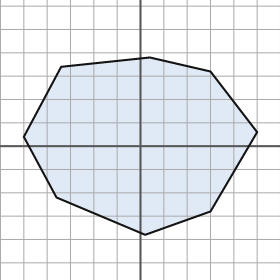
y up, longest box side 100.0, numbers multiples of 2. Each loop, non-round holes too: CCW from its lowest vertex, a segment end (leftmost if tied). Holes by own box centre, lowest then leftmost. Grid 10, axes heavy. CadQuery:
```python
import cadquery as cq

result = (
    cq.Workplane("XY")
    .moveTo(2.0, -38.0)
    .lineTo(30.0, -28.0)
    .lineTo(50.0, 6.0)
    .lineTo(30.0, 32.0)
    .lineTo(4.0, 38.0)
    .lineTo(-34.0, 34.0)
    .lineTo(-50.0, 4.0)
    .lineTo(-36.0, -22.0)
    .close()
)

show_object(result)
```